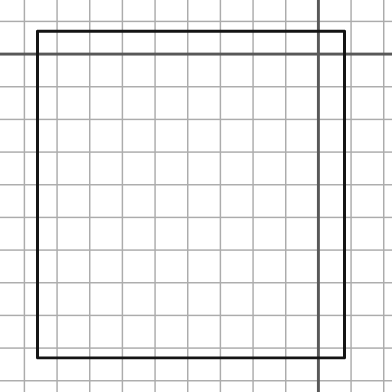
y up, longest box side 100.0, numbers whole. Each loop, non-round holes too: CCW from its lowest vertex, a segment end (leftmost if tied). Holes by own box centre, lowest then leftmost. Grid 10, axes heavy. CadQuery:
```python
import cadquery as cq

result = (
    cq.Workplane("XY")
    .moveTo(-86.0, -93.0)
    .lineTo(8.0, -93.0)
    .lineTo(8.0, 7.0)
    .lineTo(-86.0, 7.0)
    .close()
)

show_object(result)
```